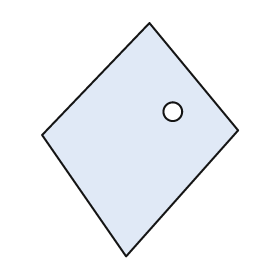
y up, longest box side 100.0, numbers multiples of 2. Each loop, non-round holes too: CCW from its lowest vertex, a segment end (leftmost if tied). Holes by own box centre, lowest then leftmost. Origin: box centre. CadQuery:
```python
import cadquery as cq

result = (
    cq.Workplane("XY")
    .moveTo(-6.0, -50.0)
    .lineTo(42.0, 4.0)
    .lineTo(4.0, 50.0)
    .lineTo(-42.0, 2.0)
    .close()
    .moveTo(14.0, 12.0)
    .circle(4.0)
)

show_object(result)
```